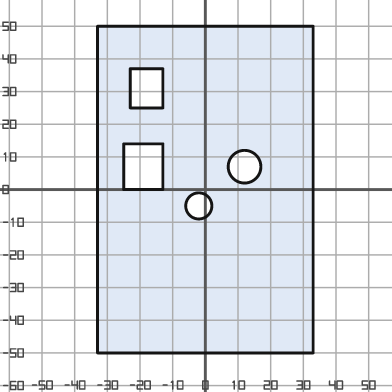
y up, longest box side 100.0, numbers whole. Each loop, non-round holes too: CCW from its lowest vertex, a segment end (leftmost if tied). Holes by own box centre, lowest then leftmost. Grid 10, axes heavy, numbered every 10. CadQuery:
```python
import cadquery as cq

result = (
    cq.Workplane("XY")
    .moveTo(-33.0, -50.0)
    .lineTo(33.0, -50.0)
    .lineTo(33.0, 50.0)
    .lineTo(-33.0, 50.0)
    .close()
    .moveTo(-2.0, -5.0)
    .circle(4.0)
    .moveTo(-25.0, 0.0)
    .lineTo(-13.0, 0.0)
    .lineTo(-13.0, 14.0)
    .lineTo(-25.0, 14.0)
    .close()
    .moveTo(12.0, 7.0)
    .circle(5.0)
    .moveTo(-23.0, 25.0)
    .lineTo(-13.0, 25.0)
    .lineTo(-13.0, 37.0)
    .lineTo(-23.0, 37.0)
    .close()
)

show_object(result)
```